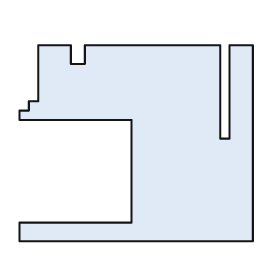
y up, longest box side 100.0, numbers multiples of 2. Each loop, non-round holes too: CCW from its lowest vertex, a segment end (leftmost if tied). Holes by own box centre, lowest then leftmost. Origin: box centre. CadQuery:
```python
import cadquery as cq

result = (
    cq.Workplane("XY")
    .moveTo(-50.0, -42.0)
    .lineTo(50.0, -42.0)
    .lineTo(50.0, 42.0)
    .lineTo(40.0, 42.0)
    .lineTo(40.0, 2.0)
    .lineTo(36.0, 2.0)
    .lineTo(36.0, 42.0)
    .lineTo(-22.0, 42.0)
    .lineTo(-22.0, 34.0)
    .lineTo(-28.0, 34.0)
    .lineTo(-28.0, 42.0)
    .lineTo(-42.0, 42.0)
    .lineTo(-42.0, 18.0)
    .lineTo(-46.0, 18.0)
    .lineTo(-46.0, 14.0)
    .lineTo(-50.0, 14.0)
    .lineTo(-50.0, 10.0)
    .lineTo(-2.0, 10.0)
    .lineTo(-2.0, -34.0)
    .lineTo(-50.0, -34.0)
    .close()
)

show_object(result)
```